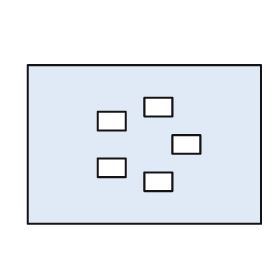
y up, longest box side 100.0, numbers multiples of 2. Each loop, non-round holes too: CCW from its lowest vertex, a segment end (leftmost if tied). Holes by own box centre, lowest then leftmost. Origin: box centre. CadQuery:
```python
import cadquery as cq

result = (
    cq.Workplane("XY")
    .moveTo(-50.0, -34.0)
    .lineTo(50.0, -34.0)
    .lineTo(50.0, 34.0)
    .lineTo(-50.0, 34.0)
    .close()
    .moveTo(0.0, -20.0)
    .lineTo(12.0, -20.0)
    .lineTo(12.0, -12.0)
    .lineTo(0.0, -12.0)
    .close()
    .moveTo(-20.0, -14.0)
    .lineTo(-8.0, -14.0)
    .lineTo(-8.0, -6.0)
    .lineTo(-20.0, -6.0)
    .close()
    .moveTo(12.0, -4.0)
    .lineTo(24.0, -4.0)
    .lineTo(24.0, 4.0)
    .lineTo(12.0, 4.0)
    .close()
    .moveTo(-20.0, 6.0)
    .lineTo(-8.0, 6.0)
    .lineTo(-8.0, 14.0)
    .lineTo(-20.0, 14.0)
    .close()
    .moveTo(0.0, 12.0)
    .lineTo(12.0, 12.0)
    .lineTo(12.0, 20.0)
    .lineTo(0.0, 20.0)
    .close()
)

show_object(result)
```